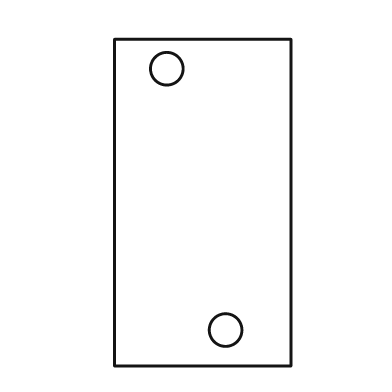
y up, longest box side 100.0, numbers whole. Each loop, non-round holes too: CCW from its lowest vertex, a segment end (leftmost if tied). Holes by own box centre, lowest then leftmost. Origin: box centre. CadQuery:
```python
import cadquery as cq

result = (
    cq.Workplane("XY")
    .moveTo(-27.0, -50.0)
    .lineTo(27.0, -50.0)
    .lineTo(27.0, 50.0)
    .lineTo(-27.0, 50.0)
    .close()
    .moveTo(7.0, -39.0)
    .circle(5.0)
    .moveTo(-11.0, 41.0)
    .circle(5.0)
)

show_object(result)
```